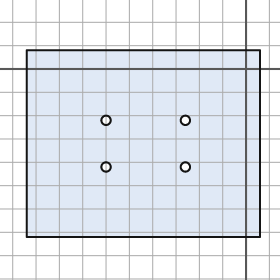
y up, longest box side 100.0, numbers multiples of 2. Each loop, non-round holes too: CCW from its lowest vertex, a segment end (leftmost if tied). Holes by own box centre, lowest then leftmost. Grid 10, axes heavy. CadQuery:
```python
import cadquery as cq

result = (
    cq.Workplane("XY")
    .moveTo(-94.0, -72.0)
    .lineTo(6.0, -72.0)
    .lineTo(6.0, 8.0)
    .lineTo(-94.0, 8.0)
    .close()
    .moveTo(-60.0, -42.0)
    .circle(2.0)
    .moveTo(-26.0, -42.0)
    .circle(2.0)
    .moveTo(-60.0, -22.0)
    .circle(2.0)
    .moveTo(-26.0, -22.0)
    .circle(2.0)
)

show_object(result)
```